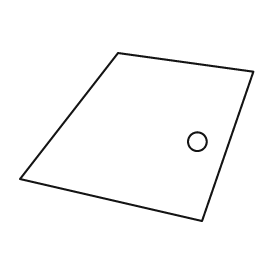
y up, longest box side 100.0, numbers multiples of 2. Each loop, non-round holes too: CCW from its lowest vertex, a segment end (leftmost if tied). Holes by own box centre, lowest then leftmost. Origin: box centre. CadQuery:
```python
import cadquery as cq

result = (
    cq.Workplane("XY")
    .moveTo(28.0, -36.0)
    .lineTo(50.0, 28.0)
    .lineTo(-8.0, 36.0)
    .lineTo(-50.0, -18.0)
    .close()
    .moveTo(26.0, -2.0)
    .circle(4.0)
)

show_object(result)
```